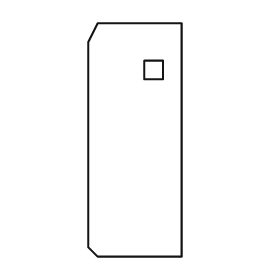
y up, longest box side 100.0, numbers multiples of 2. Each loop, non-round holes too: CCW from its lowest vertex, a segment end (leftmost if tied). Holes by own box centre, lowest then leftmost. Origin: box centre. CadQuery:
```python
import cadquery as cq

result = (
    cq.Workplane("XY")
    .moveTo(-16.0, -50.0)
    .lineTo(20.0, -50.0)
    .lineTo(20.0, 50.0)
    .lineTo(-16.0, 50.0)
    .lineTo(-20.0, 42.0)
    .lineTo(-20.0, -46.0)
    .close()
    .moveTo(4.0, 26.0)
    .lineTo(12.0, 26.0)
    .lineTo(12.0, 34.0)
    .lineTo(4.0, 34.0)
    .close()
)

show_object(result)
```